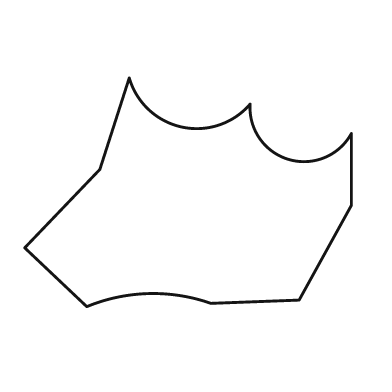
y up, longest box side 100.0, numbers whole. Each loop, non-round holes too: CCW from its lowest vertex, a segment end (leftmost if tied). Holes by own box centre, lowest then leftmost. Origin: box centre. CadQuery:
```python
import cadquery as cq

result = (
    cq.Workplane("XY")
    .moveTo(-31.0, -35.0)
    .threePointArc((-12.0, -31.0), (7.0, -34.0))
    .lineTo(34.0, -33.0)
    .lineTo(50.0, -4.0)
    .lineTo(50.0, 18.0)
    .threePointArc((31.0, 10.0), (19.0, 27.0))
    .threePointArc((-2.0, 20.0), (-18.0, 35.0))
    .lineTo(-27.0, 7.0)
    .lineTo(-50.0, -17.0)
    .close()
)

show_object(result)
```